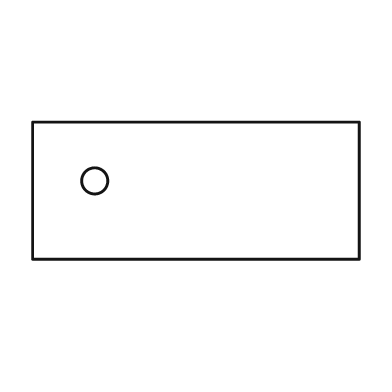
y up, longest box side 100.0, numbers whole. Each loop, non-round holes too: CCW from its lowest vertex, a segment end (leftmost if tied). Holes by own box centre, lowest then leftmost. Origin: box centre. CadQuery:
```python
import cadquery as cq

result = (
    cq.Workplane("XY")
    .moveTo(-50.0, -21.0)
    .lineTo(50.0, -21.0)
    .lineTo(50.0, 21.0)
    .lineTo(-50.0, 21.0)
    .close()
    .moveTo(-31.0, 3.0)
    .circle(4.0)
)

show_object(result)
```